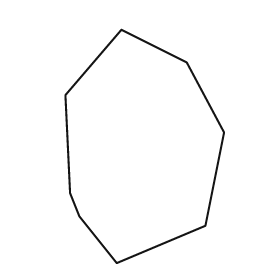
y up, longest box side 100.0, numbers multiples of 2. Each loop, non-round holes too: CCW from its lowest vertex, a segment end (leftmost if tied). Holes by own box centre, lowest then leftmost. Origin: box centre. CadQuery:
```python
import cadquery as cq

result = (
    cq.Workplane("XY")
    .moveTo(-12.0, -50.0)
    .lineTo(26.0, -34.0)
    .lineTo(34.0, 6.0)
    .lineTo(18.0, 36.0)
    .lineTo(-10.0, 50.0)
    .lineTo(-34.0, 22.0)
    .lineTo(-32.0, -20.0)
    .lineTo(-28.0, -30.0)
    .close()
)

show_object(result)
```